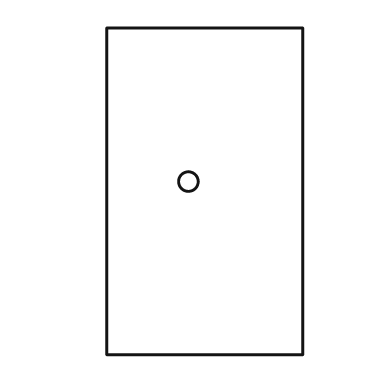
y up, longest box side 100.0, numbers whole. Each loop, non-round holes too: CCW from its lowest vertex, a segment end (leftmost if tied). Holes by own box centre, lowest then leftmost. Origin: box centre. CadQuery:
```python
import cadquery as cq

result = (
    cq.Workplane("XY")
    .moveTo(-30.0, -50.0)
    .lineTo(30.0, -50.0)
    .lineTo(30.0, 50.0)
    .lineTo(-30.0, 50.0)
    .close()
    .moveTo(-5.0, 3.0)
    .circle(3.0)
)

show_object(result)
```